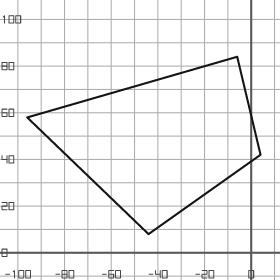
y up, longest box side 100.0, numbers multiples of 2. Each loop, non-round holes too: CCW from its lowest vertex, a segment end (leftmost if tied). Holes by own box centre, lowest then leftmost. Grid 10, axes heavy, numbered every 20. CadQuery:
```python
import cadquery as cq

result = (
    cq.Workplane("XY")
    .moveTo(-44.0, 8.0)
    .lineTo(4.0, 42.0)
    .lineTo(-6.0, 84.0)
    .lineTo(-96.0, 58.0)
    .close()
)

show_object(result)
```